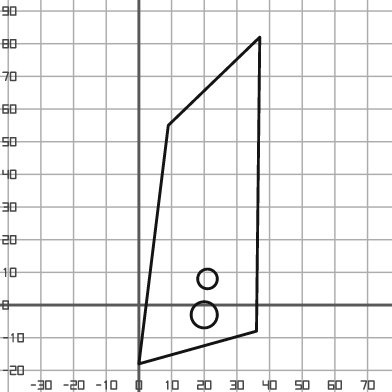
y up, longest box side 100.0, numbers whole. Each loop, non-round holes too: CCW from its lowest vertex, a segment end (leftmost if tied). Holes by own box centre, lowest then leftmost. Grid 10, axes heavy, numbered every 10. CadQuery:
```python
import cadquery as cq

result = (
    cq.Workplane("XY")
    .moveTo(0.0, -18.0)
    .lineTo(36.0, -8.0)
    .lineTo(37.0, 82.0)
    .lineTo(9.0, 55.0)
    .close()
    .moveTo(20.0, -3.0)
    .circle(4.0)
    .moveTo(21.0, 8.0)
    .circle(3.0)
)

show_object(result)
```